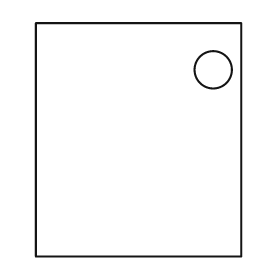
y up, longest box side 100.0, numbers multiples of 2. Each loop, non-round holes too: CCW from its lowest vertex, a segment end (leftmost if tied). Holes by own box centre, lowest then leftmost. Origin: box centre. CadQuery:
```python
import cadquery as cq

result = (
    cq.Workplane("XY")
    .moveTo(-44.0, -50.0)
    .lineTo(44.0, -50.0)
    .lineTo(44.0, 50.0)
    .lineTo(-44.0, 50.0)
    .close()
    .moveTo(32.0, 30.0)
    .circle(8.0)
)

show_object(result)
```